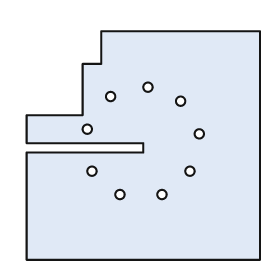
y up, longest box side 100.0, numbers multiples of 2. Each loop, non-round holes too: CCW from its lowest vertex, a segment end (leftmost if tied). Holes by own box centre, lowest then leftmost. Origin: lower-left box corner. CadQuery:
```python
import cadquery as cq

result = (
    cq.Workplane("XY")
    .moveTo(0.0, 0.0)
    .lineTo(100.0, 0.0)
    .lineTo(100.0, 98.0)
    .lineTo(32.0, 98.0)
    .lineTo(32.0, 84.0)
    .lineTo(24.0, 84.0)
    .lineTo(24.0, 62.0)
    .lineTo(0.0, 62.0)
    .lineTo(0.0, 50.0)
    .lineTo(50.0, 50.0)
    .lineTo(50.0, 46.0)
    .lineTo(0.0, 46.0)
    .close()
    .moveTo(40.0, 28.0)
    .circle(2.0)
    .moveTo(58.0, 28.0)
    .circle(2.0)
    .moveTo(28.0, 38.0)
    .circle(2.0)
    .moveTo(70.0, 38.0)
    .circle(2.0)
    .moveTo(74.0, 54.0)
    .circle(2.0)
    .moveTo(26.0, 56.0)
    .circle(2.0)
    .moveTo(66.0, 68.0)
    .circle(2.0)
    .moveTo(36.0, 70.0)
    .circle(2.0)
    .moveTo(52.0, 74.0)
    .circle(2.0)
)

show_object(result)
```